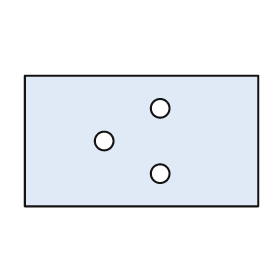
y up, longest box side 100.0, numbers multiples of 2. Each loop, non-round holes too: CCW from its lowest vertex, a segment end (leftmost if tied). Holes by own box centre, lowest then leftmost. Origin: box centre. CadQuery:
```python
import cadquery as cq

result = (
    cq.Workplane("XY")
    .moveTo(-50.0, -28.0)
    .lineTo(50.0, -28.0)
    .lineTo(50.0, 28.0)
    .lineTo(-50.0, 28.0)
    .close()
    .moveTo(8.0, -14.0)
    .circle(4.0)
    .moveTo(-16.0, 0.0)
    .circle(4.0)
    .moveTo(8.0, 14.0)
    .circle(4.0)
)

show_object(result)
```